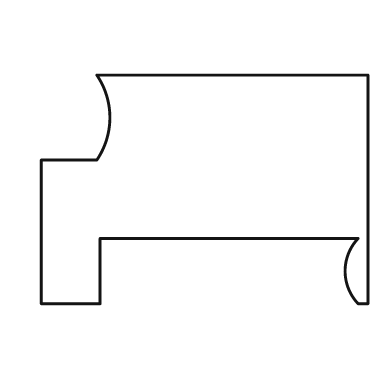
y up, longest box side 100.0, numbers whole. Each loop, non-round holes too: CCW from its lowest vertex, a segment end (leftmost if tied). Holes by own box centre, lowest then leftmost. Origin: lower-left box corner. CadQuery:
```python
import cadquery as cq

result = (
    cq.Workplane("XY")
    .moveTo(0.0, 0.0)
    .lineTo(18.0, 0.0)
    .lineTo(18.0, 20.0)
    .lineTo(97.0, 20.0)
    .threePointArc((93.0, 10.0), (97.0, 0.0))
    .lineTo(100.0, 0.0)
    .lineTo(100.0, 70.0)
    .lineTo(17.0, 70.0)
    .threePointArc((21.0, 57.0), (17.0, 44.0))
    .lineTo(0.0, 44.0)
    .close()
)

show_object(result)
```